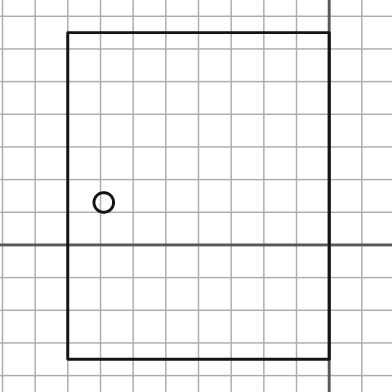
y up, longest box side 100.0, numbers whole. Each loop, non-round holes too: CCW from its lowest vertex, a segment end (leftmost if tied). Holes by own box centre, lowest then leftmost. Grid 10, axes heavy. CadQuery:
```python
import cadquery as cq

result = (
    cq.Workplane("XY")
    .moveTo(-80.0, -35.0)
    .lineTo(0.0, -35.0)
    .lineTo(0.0, 65.0)
    .lineTo(-80.0, 65.0)
    .close()
    .moveTo(-69.0, 13.0)
    .circle(3.0)
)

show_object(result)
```